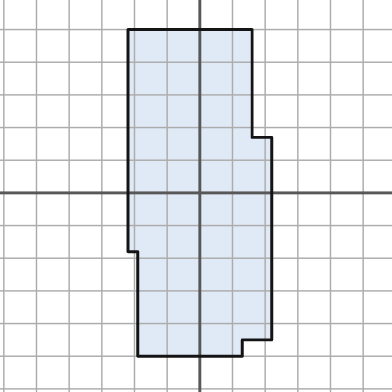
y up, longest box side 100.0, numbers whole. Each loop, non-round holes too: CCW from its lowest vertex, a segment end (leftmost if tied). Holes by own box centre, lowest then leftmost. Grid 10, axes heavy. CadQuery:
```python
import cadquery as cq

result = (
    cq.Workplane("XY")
    .moveTo(-19.0, -50.0)
    .lineTo(13.0, -50.0)
    .lineTo(13.0, -45.0)
    .lineTo(22.0, -45.0)
    .lineTo(22.0, 17.0)
    .lineTo(16.0, 17.0)
    .lineTo(16.0, 50.0)
    .lineTo(-22.0, 50.0)
    .lineTo(-22.0, -18.0)
    .lineTo(-19.0, -18.0)
    .close()
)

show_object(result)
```